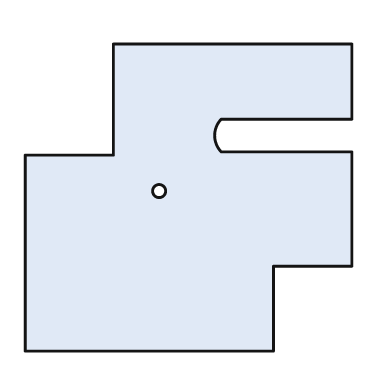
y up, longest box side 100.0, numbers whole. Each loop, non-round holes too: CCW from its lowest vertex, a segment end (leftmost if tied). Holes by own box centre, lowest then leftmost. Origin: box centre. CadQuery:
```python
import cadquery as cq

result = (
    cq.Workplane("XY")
    .moveTo(-50.0, -47.0)
    .lineTo(26.0, -47.0)
    .lineTo(26.0, -21.0)
    .lineTo(50.0, -21.0)
    .lineTo(50.0, 14.0)
    .lineTo(10.0, 14.0)
    .threePointArc((8.0, 19.0), (10.0, 24.0))
    .lineTo(50.0, 24.0)
    .lineTo(50.0, 47.0)
    .lineTo(-23.0, 47.0)
    .lineTo(-23.0, 13.0)
    .lineTo(-50.0, 13.0)
    .close()
    .moveTo(-9.0, 2.0)
    .circle(2.0)
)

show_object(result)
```